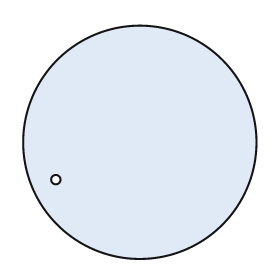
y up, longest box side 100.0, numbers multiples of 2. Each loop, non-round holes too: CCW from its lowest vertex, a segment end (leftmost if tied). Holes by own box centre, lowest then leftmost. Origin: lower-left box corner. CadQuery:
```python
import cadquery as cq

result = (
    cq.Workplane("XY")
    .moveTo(50.0, 50.0)
    .circle(50.0)
    .moveTo(14.0, 34.0)
    .circle(2.0)
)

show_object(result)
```